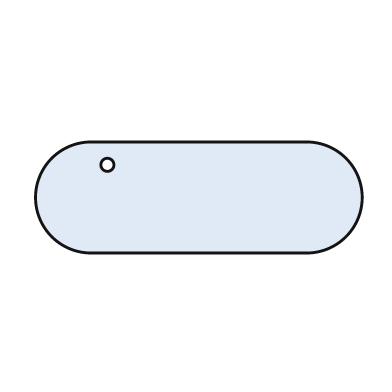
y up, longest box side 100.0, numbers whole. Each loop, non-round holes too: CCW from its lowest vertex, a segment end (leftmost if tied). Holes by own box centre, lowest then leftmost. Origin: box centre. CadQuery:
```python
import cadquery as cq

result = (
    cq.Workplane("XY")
    .moveTo(-33.0, -17.0)
    .lineTo(33.0, -17.0)
    .threePointArc((50.0, 0.0), (33.0, 17.0))
    .lineTo(-33.0, 17.0)
    .threePointArc((-50.0, 0.0), (-33.0, -17.0))
    .close()
    .moveTo(-28.0, 10.0)
    .circle(2.0)
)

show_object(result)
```